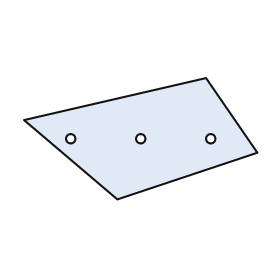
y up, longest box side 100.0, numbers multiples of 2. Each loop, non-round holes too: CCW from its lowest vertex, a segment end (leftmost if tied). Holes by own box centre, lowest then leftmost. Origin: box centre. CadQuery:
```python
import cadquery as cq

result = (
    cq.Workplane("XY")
    .moveTo(-10.0, -26.0)
    .lineTo(50.0, -6.0)
    .lineTo(28.0, 26.0)
    .lineTo(-50.0, 8.0)
    .close()
    .moveTo(-30.0, 0.0)
    .circle(2.0)
    .moveTo(0.0, 0.0)
    .circle(2.0)
    .moveTo(30.0, 0.0)
    .circle(2.0)
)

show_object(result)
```